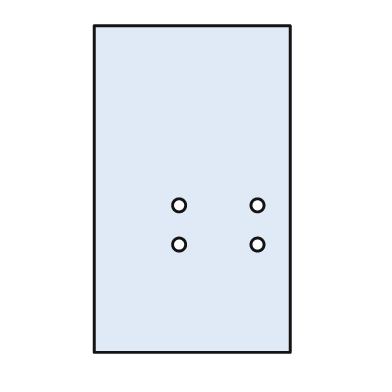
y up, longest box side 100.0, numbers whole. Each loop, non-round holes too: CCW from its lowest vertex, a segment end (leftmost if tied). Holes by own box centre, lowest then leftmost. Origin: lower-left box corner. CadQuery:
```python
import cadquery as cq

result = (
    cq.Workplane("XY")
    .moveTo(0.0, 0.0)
    .lineTo(60.0, 0.0)
    .lineTo(60.0, 100.0)
    .lineTo(0.0, 100.0)
    .close()
    .moveTo(26.0, 33.0)
    .circle(2.0)
    .moveTo(50.0, 33.0)
    .circle(2.0)
    .moveTo(26.0, 45.0)
    .circle(2.0)
    .moveTo(50.0, 45.0)
    .circle(2.0)
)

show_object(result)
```